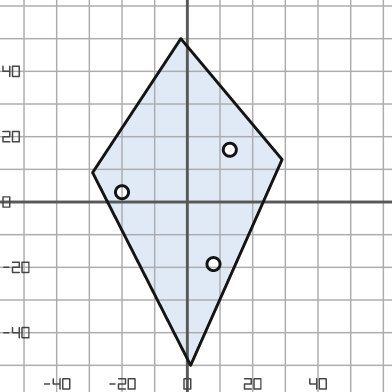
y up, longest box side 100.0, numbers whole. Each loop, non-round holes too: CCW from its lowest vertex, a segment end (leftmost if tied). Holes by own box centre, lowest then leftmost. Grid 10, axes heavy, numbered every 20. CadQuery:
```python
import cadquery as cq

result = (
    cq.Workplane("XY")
    .moveTo(1.0, -50.0)
    .lineTo(29.0, 13.0)
    .lineTo(-2.0, 50.0)
    .lineTo(-29.0, 9.0)
    .close()
    .moveTo(8.0, -19.0)
    .circle(2.0)
    .moveTo(-20.0, 3.0)
    .circle(2.0)
    .moveTo(13.0, 16.0)
    .circle(2.0)
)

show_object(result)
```